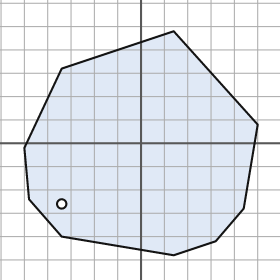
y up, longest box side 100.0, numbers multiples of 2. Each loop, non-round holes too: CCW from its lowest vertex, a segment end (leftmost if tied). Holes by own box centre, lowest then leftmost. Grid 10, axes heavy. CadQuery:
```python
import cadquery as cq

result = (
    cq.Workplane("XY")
    .moveTo(14.0, -48.0)
    .lineTo(32.0, -42.0)
    .lineTo(44.0, -28.0)
    .lineTo(50.0, 8.0)
    .lineTo(14.0, 48.0)
    .lineTo(-34.0, 32.0)
    .lineTo(-50.0, -2.0)
    .lineTo(-48.0, -24.0)
    .lineTo(-34.0, -40.0)
    .close()
    .moveTo(-34.0, -26.0)
    .circle(2.0)
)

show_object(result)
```